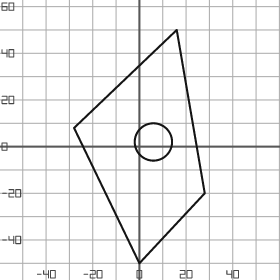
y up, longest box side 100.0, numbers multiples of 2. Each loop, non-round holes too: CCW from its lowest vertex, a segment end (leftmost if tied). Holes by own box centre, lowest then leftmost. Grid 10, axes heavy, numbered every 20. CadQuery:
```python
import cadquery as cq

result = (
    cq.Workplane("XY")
    .moveTo(0.0, -50.0)
    .lineTo(28.0, -20.0)
    .lineTo(16.0, 50.0)
    .lineTo(-28.0, 8.0)
    .close()
    .moveTo(6.0, 2.0)
    .circle(8.0)
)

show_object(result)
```